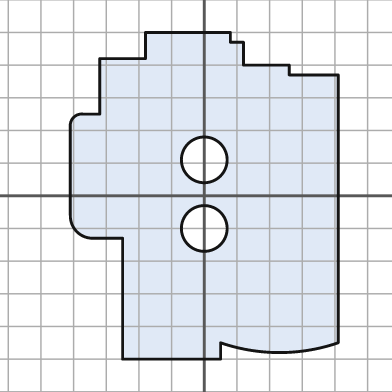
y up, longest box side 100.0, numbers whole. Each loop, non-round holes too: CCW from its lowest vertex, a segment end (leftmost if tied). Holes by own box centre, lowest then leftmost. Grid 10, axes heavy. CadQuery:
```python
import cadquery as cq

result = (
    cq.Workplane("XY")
    .moveTo(-25.0, -50.0)
    .lineTo(5.0, -50.0)
    .lineTo(5.0, -45.0)
    .threePointArc((23.0, -48.0), (41.0, -45.0))
    .lineTo(41.0, 37.0)
    .lineTo(26.0, 37.0)
    .lineTo(26.0, 40.0)
    .lineTo(12.0, 40.0)
    .lineTo(12.0, 47.0)
    .lineTo(8.0, 47.0)
    .lineTo(8.0, 50.0)
    .lineTo(-18.0, 50.0)
    .lineTo(-18.0, 42.0)
    .lineTo(-32.0, 42.0)
    .lineTo(-32.0, 25.0)
    .lineTo(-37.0, 25.0)
    .threePointArc((-40.0, 24.0), (-41.0, 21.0))
    .lineTo(-41.0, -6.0)
    .threePointArc((-39.0, -11.0), (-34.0, -13.0))
    .lineTo(-25.0, -13.0)
    .close()
    .moveTo(0.0, -10.0)
    .circle(7.0)
    .moveTo(0.0, 11.0)
    .circle(7.0)
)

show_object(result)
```